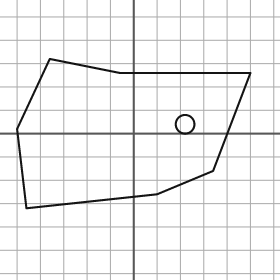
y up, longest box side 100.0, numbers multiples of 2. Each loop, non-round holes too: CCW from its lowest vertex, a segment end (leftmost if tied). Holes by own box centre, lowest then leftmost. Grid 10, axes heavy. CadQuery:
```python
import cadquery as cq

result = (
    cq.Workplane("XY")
    .moveTo(-46.0, -32.0)
    .lineTo(10.0, -26.0)
    .lineTo(34.0, -16.0)
    .lineTo(50.0, 26.0)
    .lineTo(-6.0, 26.0)
    .lineTo(-36.0, 32.0)
    .lineTo(-50.0, 2.0)
    .close()
    .moveTo(22.0, 4.0)
    .circle(4.0)
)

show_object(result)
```